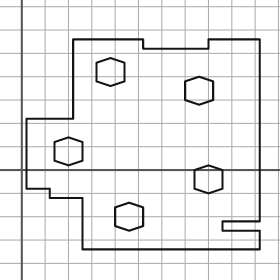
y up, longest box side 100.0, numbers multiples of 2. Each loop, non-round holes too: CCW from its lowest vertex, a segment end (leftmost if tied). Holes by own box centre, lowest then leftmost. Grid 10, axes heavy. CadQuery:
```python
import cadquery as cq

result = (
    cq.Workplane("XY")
    .moveTo(26.0, -34.0)
    .lineTo(102.0, -34.0)
    .lineTo(102.0, -26.0)
    .lineTo(86.0, -26.0)
    .lineTo(86.0, -22.0)
    .lineTo(102.0, -22.0)
    .lineTo(102.0, 56.0)
    .lineTo(80.0, 56.0)
    .lineTo(80.0, 52.0)
    .lineTo(52.0, 52.0)
    .lineTo(52.0, 56.0)
    .lineTo(22.0, 56.0)
    .lineTo(22.0, 22.0)
    .lineTo(2.0, 22.0)
    .lineTo(2.0, -8.0)
    .lineTo(12.0, -8.0)
    .lineTo(12.0, -12.0)
    .lineTo(26.0, -12.0)
    .close()
    .moveTo(46.0, -26.0)
    .lineTo(52.0, -24.0)
    .lineTo(52.0, -16.0)
    .lineTo(46.0, -14.0)
    .lineTo(40.0, -16.0)
    .lineTo(40.0, -24.0)
    .close()
    .moveTo(80.0, -10.0)
    .lineTo(86.0, -8.0)
    .lineTo(86.0, 0.0)
    .lineTo(80.0, 2.0)
    .lineTo(74.0, 0.0)
    .lineTo(74.0, -8.0)
    .close()
    .moveTo(20.0, 2.0)
    .lineTo(26.0, 4.0)
    .lineTo(26.0, 12.0)
    .lineTo(20.0, 14.0)
    .lineTo(14.0, 12.0)
    .lineTo(14.0, 4.0)
    .close()
    .moveTo(76.0, 28.0)
    .lineTo(82.0, 30.0)
    .lineTo(82.0, 38.0)
    .lineTo(76.0, 40.0)
    .lineTo(70.0, 38.0)
    .lineTo(70.0, 30.0)
    .close()
    .moveTo(38.0, 36.0)
    .lineTo(44.0, 38.0)
    .lineTo(44.0, 46.0)
    .lineTo(38.0, 48.0)
    .lineTo(32.0, 46.0)
    .lineTo(32.0, 38.0)
    .close()
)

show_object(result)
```